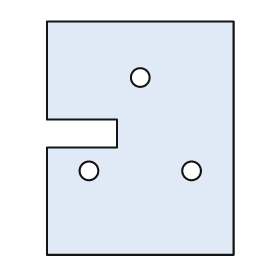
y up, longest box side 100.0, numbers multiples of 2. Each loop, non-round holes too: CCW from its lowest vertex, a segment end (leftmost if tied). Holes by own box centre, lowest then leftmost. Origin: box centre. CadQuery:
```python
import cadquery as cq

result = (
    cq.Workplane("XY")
    .moveTo(-40.0, -50.0)
    .lineTo(40.0, -50.0)
    .lineTo(40.0, 50.0)
    .lineTo(-40.0, 50.0)
    .lineTo(-40.0, 8.0)
    .lineTo(-10.0, 8.0)
    .lineTo(-10.0, -4.0)
    .lineTo(-40.0, -4.0)
    .close()
    .moveTo(-22.0, -14.0)
    .circle(4.0)
    .moveTo(22.0, -14.0)
    .circle(4.0)
    .moveTo(0.0, 26.0)
    .circle(4.0)
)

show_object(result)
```